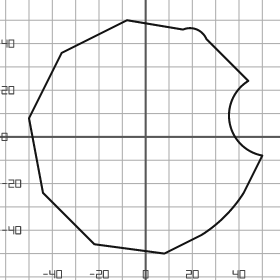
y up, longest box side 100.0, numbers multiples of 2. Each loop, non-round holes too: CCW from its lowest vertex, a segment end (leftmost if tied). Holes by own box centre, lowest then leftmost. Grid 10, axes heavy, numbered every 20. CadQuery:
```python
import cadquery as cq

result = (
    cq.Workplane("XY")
    .moveTo(8.0, -50.0)
    .lineTo(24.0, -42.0)
    .threePointArc((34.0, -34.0), (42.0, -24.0))
    .lineTo(50.0, -8.0)
    .threePointArc((36.0, 6.0), (44.0, 24.0))
    .lineTo(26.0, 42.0)
    .threePointArc((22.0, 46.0), (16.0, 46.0))
    .lineTo(-8.0, 50.0)
    .lineTo(-36.0, 36.0)
    .lineTo(-50.0, 8.0)
    .lineTo(-44.0, -24.0)
    .lineTo(-22.0, -46.0)
    .close()
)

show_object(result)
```